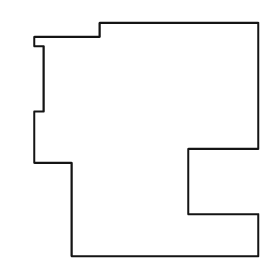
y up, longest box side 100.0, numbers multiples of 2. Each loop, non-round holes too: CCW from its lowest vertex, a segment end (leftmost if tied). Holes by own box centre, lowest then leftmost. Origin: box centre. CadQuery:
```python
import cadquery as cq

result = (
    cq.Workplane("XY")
    .moveTo(-32.0, -50.0)
    .lineTo(48.0, -50.0)
    .lineTo(48.0, -32.0)
    .lineTo(18.0, -32.0)
    .lineTo(18.0, -4.0)
    .lineTo(48.0, -4.0)
    .lineTo(48.0, 50.0)
    .lineTo(-20.0, 50.0)
    .lineTo(-20.0, 44.0)
    .lineTo(-48.0, 44.0)
    .lineTo(-48.0, 40.0)
    .lineTo(-44.0, 40.0)
    .lineTo(-44.0, 12.0)
    .lineTo(-48.0, 12.0)
    .lineTo(-48.0, -10.0)
    .lineTo(-32.0, -10.0)
    .close()
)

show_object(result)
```